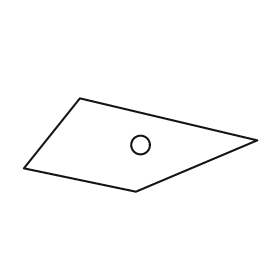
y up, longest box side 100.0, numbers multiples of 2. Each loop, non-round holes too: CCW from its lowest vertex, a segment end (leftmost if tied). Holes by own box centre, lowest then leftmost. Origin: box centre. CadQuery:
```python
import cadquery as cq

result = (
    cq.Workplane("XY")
    .moveTo(-2.0, -20.0)
    .lineTo(50.0, 2.0)
    .lineTo(-26.0, 20.0)
    .lineTo(-50.0, -10.0)
    .close()
    .moveTo(0.0, 0.0)
    .circle(4.0)
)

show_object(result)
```